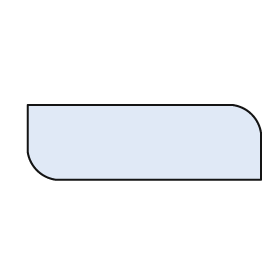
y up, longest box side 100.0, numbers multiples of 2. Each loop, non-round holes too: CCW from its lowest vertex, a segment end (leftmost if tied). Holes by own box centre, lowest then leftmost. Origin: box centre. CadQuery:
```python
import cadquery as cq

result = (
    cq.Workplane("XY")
    .moveTo(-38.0, -16.0)
    .lineTo(50.0, -16.0)
    .lineTo(50.0, 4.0)
    .threePointArc((46.0, 12.0), (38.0, 16.0))
    .lineTo(-50.0, 16.0)
    .lineTo(-50.0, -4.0)
    .threePointArc((-46.0, -12.0), (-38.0, -16.0))
    .close()
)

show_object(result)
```